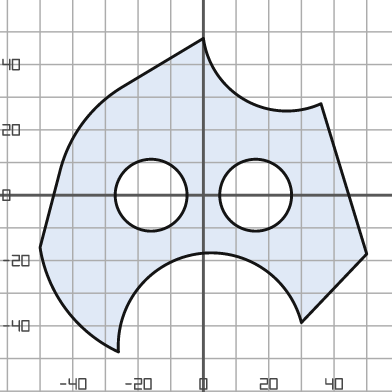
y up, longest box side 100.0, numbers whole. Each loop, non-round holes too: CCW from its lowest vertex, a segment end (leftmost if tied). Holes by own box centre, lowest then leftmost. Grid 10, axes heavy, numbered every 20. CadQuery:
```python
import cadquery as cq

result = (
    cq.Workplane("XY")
    .moveTo(-26.0, -48.0)
    .threePointArc((-2.0, -18.0), (30.0, -39.0))
    .lineTo(50.0, -18.0)
    .lineTo(36.0, 28.0)
    .threePointArc((13.0, 29.0), (0.0, 48.0))
    .lineTo(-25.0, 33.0)
    .threePointArc((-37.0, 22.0), (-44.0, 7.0))
    .lineTo(-50.0, -16.0)
    .threePointArc((-42.0, -35.0), (-26.0, -48.0))
    .close()
    .moveTo(-16.0, 0.0)
    .circle(11.0)
    .moveTo(16.0, 0.0)
    .circle(11.0)
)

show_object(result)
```